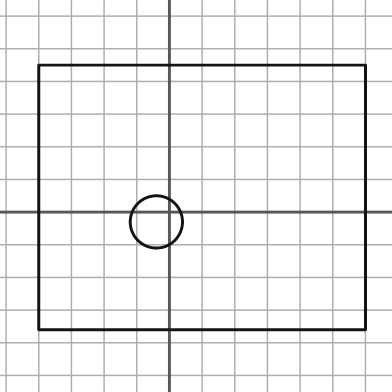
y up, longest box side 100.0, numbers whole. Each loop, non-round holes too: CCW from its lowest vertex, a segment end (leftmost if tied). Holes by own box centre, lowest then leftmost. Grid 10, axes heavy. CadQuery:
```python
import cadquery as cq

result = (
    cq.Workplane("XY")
    .moveTo(-40.0, -36.0)
    .lineTo(60.0, -36.0)
    .lineTo(60.0, 45.0)
    .lineTo(-40.0, 45.0)
    .close()
    .moveTo(-4.0, -3.0)
    .circle(8.0)
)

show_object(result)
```